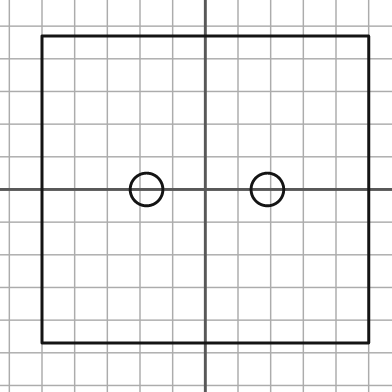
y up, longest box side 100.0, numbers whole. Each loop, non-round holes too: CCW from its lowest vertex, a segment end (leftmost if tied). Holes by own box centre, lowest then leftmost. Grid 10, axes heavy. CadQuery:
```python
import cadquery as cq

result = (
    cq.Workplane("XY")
    .moveTo(-50.0, -47.0)
    .lineTo(50.0, -47.0)
    .lineTo(50.0, 47.0)
    .lineTo(-50.0, 47.0)
    .close()
    .moveTo(-18.0, 0.0)
    .circle(5.0)
    .moveTo(19.0, 0.0)
    .circle(5.0)
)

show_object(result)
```